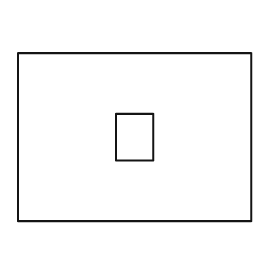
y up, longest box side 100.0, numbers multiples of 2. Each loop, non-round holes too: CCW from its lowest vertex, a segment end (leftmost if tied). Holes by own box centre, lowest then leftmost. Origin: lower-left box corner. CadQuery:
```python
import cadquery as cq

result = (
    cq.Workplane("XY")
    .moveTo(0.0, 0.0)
    .lineTo(100.0, 0.0)
    .lineTo(100.0, 72.0)
    .lineTo(0.0, 72.0)
    .close()
    .moveTo(42.0, 26.0)
    .lineTo(58.0, 26.0)
    .lineTo(58.0, 46.0)
    .lineTo(42.0, 46.0)
    .close()
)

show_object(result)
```